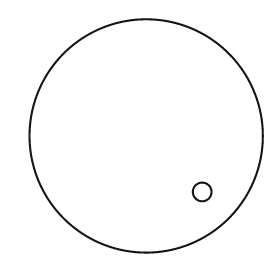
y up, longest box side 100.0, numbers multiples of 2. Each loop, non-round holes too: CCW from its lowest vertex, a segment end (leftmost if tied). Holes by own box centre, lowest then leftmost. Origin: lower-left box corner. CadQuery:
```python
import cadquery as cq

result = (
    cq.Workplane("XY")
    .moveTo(50.0, 50.0)
    .circle(50.0)
    .moveTo(74.0, 26.0)
    .circle(4.0)
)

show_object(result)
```